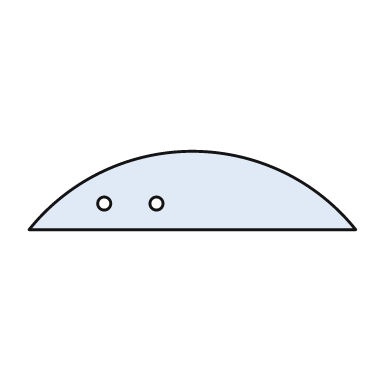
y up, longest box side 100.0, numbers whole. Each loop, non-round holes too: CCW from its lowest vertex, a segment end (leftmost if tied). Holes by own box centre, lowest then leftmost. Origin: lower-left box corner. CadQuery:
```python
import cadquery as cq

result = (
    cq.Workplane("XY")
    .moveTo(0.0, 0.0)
    .lineTo(100.0, 0.0)
    .threePointArc((50.0, 24.0), (0.0, 0.0))
    .close()
    .moveTo(23.0, 8.0)
    .circle(2.0)
    .moveTo(39.0, 8.0)
    .circle(2.0)
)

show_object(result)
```